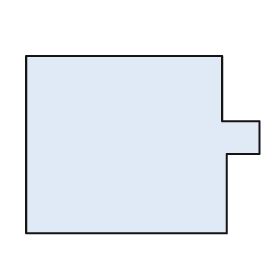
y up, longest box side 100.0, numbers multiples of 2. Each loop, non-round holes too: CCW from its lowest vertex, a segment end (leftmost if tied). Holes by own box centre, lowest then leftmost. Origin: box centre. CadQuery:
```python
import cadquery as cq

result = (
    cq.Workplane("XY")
    .moveTo(-50.0, -38.0)
    .lineTo(36.0, -38.0)
    .lineTo(36.0, -4.0)
    .lineTo(50.0, -4.0)
    .lineTo(50.0, 10.0)
    .lineTo(34.0, 10.0)
    .lineTo(34.0, 38.0)
    .lineTo(-50.0, 38.0)
    .close()
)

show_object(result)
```